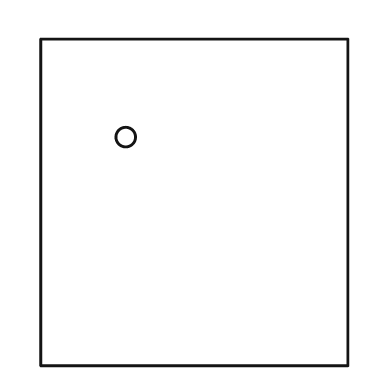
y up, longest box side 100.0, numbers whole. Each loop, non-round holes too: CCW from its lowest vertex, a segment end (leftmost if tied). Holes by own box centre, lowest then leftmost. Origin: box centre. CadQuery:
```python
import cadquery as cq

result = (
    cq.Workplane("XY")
    .moveTo(-47.0, -50.0)
    .lineTo(47.0, -50.0)
    .lineTo(47.0, 50.0)
    .lineTo(-47.0, 50.0)
    .close()
    .moveTo(-21.0, 20.0)
    .circle(3.0)
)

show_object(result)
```